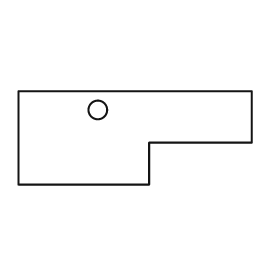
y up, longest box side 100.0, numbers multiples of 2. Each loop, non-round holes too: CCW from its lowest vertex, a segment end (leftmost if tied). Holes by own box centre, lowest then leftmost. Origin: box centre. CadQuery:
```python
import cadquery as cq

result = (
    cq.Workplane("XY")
    .moveTo(-50.0, -20.0)
    .lineTo(6.0, -20.0)
    .lineTo(6.0, -2.0)
    .lineTo(50.0, -2.0)
    .lineTo(50.0, 20.0)
    .lineTo(-50.0, 20.0)
    .close()
    .moveTo(-16.0, 12.0)
    .circle(4.0)
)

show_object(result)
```